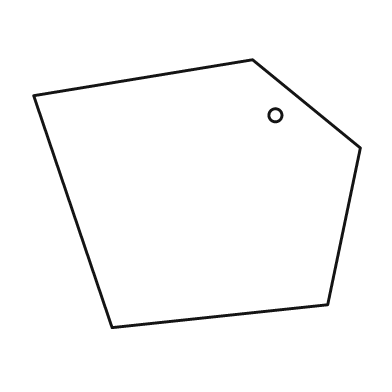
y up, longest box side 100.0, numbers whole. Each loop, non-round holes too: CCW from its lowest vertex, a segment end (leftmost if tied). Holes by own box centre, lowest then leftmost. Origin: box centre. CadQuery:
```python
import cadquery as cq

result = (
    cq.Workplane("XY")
    .moveTo(-26.0, -41.0)
    .lineTo(40.0, -34.0)
    .lineTo(50.0, 14.0)
    .lineTo(17.0, 41.0)
    .lineTo(-50.0, 30.0)
    .close()
    .moveTo(24.0, 24.0)
    .circle(2.0)
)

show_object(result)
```